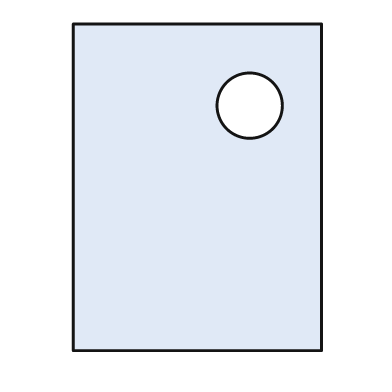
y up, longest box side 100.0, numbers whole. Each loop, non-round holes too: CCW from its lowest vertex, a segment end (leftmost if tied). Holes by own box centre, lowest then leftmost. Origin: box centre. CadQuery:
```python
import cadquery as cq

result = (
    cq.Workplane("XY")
    .moveTo(-38.0, -50.0)
    .lineTo(38.0, -50.0)
    .lineTo(38.0, 50.0)
    .lineTo(-38.0, 50.0)
    .close()
    .moveTo(16.0, 25.0)
    .circle(10.0)
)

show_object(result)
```